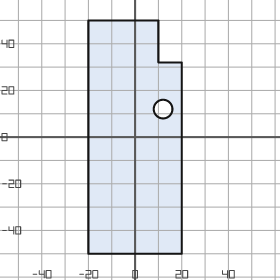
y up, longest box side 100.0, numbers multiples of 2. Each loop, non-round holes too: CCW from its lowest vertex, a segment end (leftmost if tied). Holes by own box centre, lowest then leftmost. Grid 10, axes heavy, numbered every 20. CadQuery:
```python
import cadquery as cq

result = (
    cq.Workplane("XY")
    .moveTo(-20.0, -50.0)
    .lineTo(20.0, -50.0)
    .lineTo(20.0, 32.0)
    .lineTo(10.0, 32.0)
    .lineTo(10.0, 50.0)
    .lineTo(-20.0, 50.0)
    .close()
    .moveTo(12.0, 12.0)
    .circle(4.0)
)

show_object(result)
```